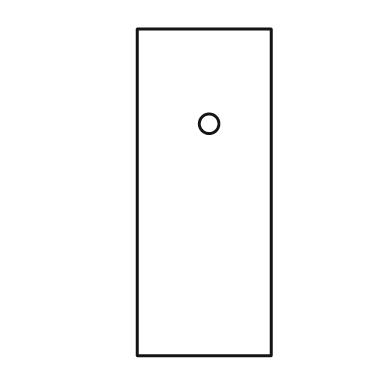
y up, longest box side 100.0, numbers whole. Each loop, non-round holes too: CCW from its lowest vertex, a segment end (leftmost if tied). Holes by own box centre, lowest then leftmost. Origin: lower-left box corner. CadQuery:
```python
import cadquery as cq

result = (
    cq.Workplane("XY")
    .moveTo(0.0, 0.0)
    .lineTo(41.0, 0.0)
    .lineTo(41.0, 100.0)
    .lineTo(0.0, 100.0)
    .close()
    .moveTo(22.0, 71.0)
    .circle(3.0)
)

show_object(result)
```